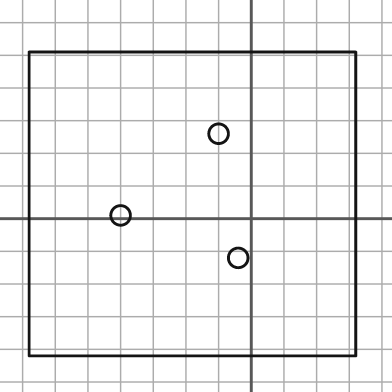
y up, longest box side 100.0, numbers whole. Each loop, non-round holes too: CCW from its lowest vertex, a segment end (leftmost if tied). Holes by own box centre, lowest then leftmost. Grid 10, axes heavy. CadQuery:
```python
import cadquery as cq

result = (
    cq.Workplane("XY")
    .moveTo(-68.0, -42.0)
    .lineTo(32.0, -42.0)
    .lineTo(32.0, 51.0)
    .lineTo(-68.0, 51.0)
    .close()
    .moveTo(-4.0, -12.0)
    .circle(3.0)
    .moveTo(-40.0, 1.0)
    .circle(3.0)
    .moveTo(-10.0, 26.0)
    .circle(3.0)
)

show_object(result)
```